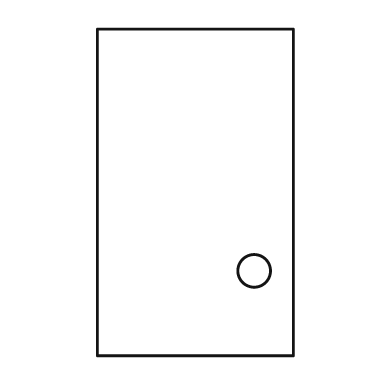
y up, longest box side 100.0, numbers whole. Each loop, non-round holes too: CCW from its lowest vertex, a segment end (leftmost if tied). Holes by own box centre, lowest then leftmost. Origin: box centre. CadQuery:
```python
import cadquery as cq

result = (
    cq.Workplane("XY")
    .moveTo(-30.0, -50.0)
    .lineTo(30.0, -50.0)
    .lineTo(30.0, 50.0)
    .lineTo(-30.0, 50.0)
    .close()
    .moveTo(18.0, -24.0)
    .circle(5.0)
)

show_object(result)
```